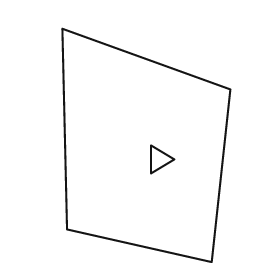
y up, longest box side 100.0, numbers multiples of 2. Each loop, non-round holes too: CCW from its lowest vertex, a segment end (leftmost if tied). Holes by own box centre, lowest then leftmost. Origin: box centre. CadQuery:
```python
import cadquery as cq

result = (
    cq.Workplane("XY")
    .moveTo(28.0, -50.0)
    .lineTo(36.0, 24.0)
    .lineTo(-36.0, 50.0)
    .lineTo(-34.0, -36.0)
    .close()
    .moveTo(2.0, -12.0)
    .lineTo(12.0, -6.0)
    .lineTo(2.0, 0.0)
    .close()
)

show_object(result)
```